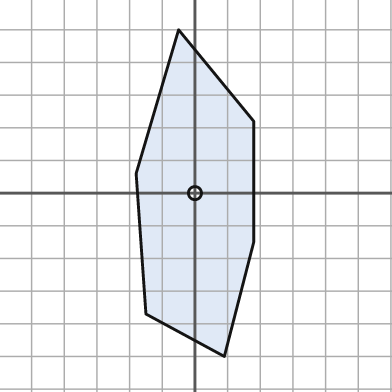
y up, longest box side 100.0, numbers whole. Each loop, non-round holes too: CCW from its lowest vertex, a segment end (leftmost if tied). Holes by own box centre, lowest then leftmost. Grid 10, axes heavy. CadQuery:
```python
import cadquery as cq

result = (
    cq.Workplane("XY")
    .moveTo(9.0, -50.0)
    .lineTo(18.0, -15.0)
    .lineTo(18.0, 22.0)
    .lineTo(-5.0, 50.0)
    .lineTo(-18.0, 6.0)
    .lineTo(-15.0, -37.0)
    .close()
    .moveTo(0.0, 0.0)
    .circle(2.0)
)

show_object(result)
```